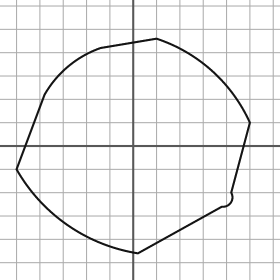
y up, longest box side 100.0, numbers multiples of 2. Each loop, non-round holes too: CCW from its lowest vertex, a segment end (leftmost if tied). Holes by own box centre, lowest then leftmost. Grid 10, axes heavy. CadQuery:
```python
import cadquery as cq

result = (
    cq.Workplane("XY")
    .moveTo(2.0, -46.0)
    .lineTo(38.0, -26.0)
    .threePointArc((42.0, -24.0), (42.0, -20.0))
    .lineTo(50.0, 10.0)
    .threePointArc((34.0, 32.0), (10.0, 46.0))
    .lineTo(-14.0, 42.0)
    .threePointArc((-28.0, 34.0), (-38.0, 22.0))
    .lineTo(-50.0, -10.0)
    .threePointArc((-28.0, -34.0), (2.0, -46.0))
    .close()
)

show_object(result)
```